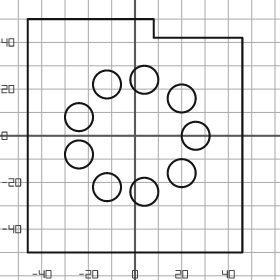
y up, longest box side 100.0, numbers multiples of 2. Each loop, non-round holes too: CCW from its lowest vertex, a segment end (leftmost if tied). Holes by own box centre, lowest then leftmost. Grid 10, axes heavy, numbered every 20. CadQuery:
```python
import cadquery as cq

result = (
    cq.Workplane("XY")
    .moveTo(-46.0, -50.0)
    .lineTo(46.0, -50.0)
    .lineTo(46.0, 42.0)
    .lineTo(8.0, 42.0)
    .lineTo(8.0, 50.0)
    .lineTo(-46.0, 50.0)
    .close()
    .moveTo(4.0, -24.0)
    .circle(6.0)
    .moveTo(-12.0, -22.0)
    .circle(6.0)
    .moveTo(20.0, -16.0)
    .circle(6.0)
    .moveTo(-24.0, -8.0)
    .circle(6.0)
    .moveTo(26.0, 0.0)
    .circle(6.0)
    .moveTo(-24.0, 8.0)
    .circle(6.0)
    .moveTo(20.0, 16.0)
    .circle(6.0)
    .moveTo(-12.0, 22.0)
    .circle(6.0)
    .moveTo(4.0, 24.0)
    .circle(6.0)
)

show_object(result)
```